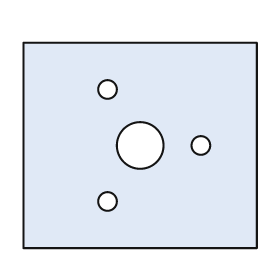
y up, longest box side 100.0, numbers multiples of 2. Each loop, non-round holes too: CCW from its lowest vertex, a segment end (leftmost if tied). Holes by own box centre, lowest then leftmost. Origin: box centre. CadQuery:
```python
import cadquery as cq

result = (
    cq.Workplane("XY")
    .moveTo(-50.0, -44.0)
    .lineTo(50.0, -44.0)
    .lineTo(50.0, 44.0)
    .lineTo(-50.0, 44.0)
    .close()
    .moveTo(-14.0, -24.0)
    .circle(4.0)
    .moveTo(0.0, 0.0)
    .circle(10.0)
    .moveTo(26.0, 0.0)
    .circle(4.0)
    .moveTo(-14.0, 24.0)
    .circle(4.0)
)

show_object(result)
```